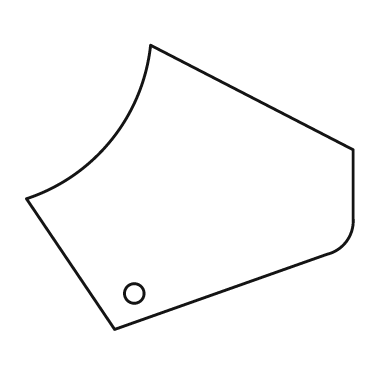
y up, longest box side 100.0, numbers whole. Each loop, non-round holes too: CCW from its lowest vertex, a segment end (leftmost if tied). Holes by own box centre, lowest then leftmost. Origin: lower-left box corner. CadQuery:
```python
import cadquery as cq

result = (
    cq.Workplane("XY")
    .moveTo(27.0, 0.0)
    .lineTo(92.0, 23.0)
    .threePointArc((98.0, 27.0), (100.0, 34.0))
    .lineTo(100.0, 55.0)
    .lineTo(38.0, 87.0)
    .threePointArc((26.0, 58.0), (0.0, 40.0))
    .close()
    .moveTo(33.0, 11.0)
    .circle(3.0)
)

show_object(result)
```